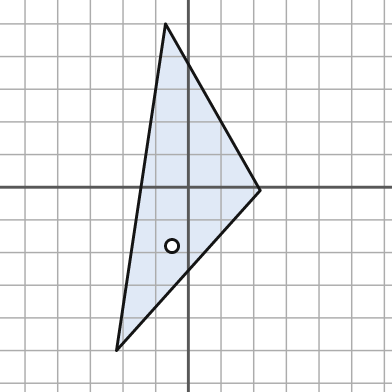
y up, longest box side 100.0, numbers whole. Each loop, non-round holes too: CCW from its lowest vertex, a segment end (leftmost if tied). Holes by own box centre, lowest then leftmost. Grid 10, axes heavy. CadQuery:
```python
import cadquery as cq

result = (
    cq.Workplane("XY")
    .moveTo(-22.0, -50.0)
    .lineTo(22.0, -1.0)
    .lineTo(-7.0, 50.0)
    .close()
    .moveTo(-5.0, -18.0)
    .circle(2.0)
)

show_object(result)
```